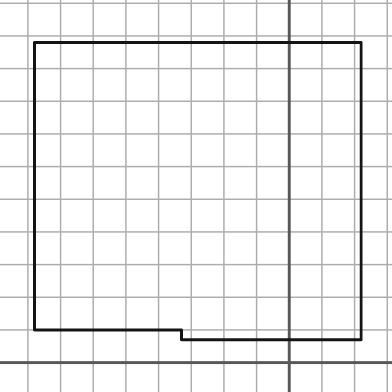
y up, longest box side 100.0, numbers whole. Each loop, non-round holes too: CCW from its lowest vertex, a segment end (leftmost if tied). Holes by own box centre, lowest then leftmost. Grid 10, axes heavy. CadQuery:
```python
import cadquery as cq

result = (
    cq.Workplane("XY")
    .moveTo(-33.0, 7.0)
    .lineTo(22.0, 7.0)
    .lineTo(22.0, 98.0)
    .lineTo(-78.0, 98.0)
    .lineTo(-78.0, 10.0)
    .lineTo(-33.0, 10.0)
    .close()
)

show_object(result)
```